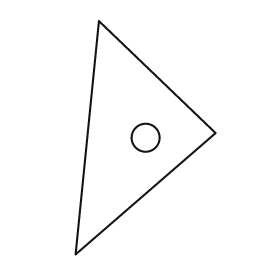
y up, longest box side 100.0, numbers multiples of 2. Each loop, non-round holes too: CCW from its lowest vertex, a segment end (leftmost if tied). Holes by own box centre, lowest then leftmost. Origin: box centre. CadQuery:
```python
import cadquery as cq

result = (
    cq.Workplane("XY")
    .moveTo(-30.0, -50.0)
    .lineTo(30.0, 2.0)
    .lineTo(-20.0, 50.0)
    .close()
    .moveTo(0.0, 0.0)
    .circle(6.0)
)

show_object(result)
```